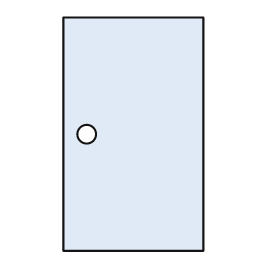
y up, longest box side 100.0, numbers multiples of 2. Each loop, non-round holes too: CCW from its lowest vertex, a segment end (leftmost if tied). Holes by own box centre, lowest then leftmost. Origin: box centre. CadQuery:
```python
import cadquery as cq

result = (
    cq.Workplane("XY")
    .moveTo(-30.0, -50.0)
    .lineTo(30.0, -50.0)
    .lineTo(30.0, 50.0)
    .lineTo(-30.0, 50.0)
    .close()
    .moveTo(-20.0, 0.0)
    .circle(4.0)
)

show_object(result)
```